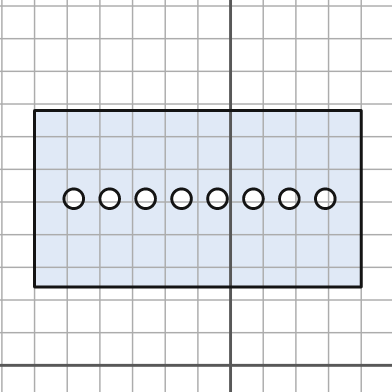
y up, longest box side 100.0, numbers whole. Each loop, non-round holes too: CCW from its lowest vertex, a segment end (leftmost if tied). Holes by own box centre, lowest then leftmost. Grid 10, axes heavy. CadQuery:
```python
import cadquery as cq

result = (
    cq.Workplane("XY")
    .moveTo(-60.0, 24.0)
    .lineTo(40.0, 24.0)
    .lineTo(40.0, 78.0)
    .lineTo(-60.0, 78.0)
    .close()
    .moveTo(-48.0, 51.0)
    .circle(3.0)
    .moveTo(-37.0, 51.0)
    .circle(3.0)
    .moveTo(-26.0, 51.0)
    .circle(3.0)
    .moveTo(-15.0, 51.0)
    .circle(3.0)
    .moveTo(-4.0, 51.0)
    .circle(3.0)
    .moveTo(7.0, 51.0)
    .circle(3.0)
    .moveTo(18.0, 51.0)
    .circle(3.0)
    .moveTo(29.0, 51.0)
    .circle(3.0)
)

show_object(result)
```